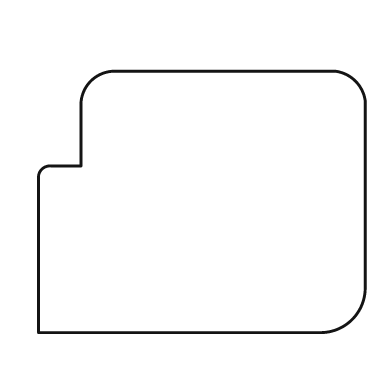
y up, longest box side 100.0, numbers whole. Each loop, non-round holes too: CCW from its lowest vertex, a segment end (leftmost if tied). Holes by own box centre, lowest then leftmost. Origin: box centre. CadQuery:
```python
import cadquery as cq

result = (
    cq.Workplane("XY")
    .moveTo(-50.0, -40.0)
    .lineTo(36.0, -40.0)
    .threePointArc((46.0, -36.0), (50.0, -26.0))
    .lineTo(50.0, 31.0)
    .threePointArc((47.0, 37.0), (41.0, 40.0))
    .lineTo(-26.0, 40.0)
    .threePointArc((-34.0, 37.0), (-37.0, 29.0))
    .lineTo(-37.0, 11.0)
    .lineTo(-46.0, 11.0)
    .threePointArc((-49.0, 10.0), (-50.0, 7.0))
    .close()
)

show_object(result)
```